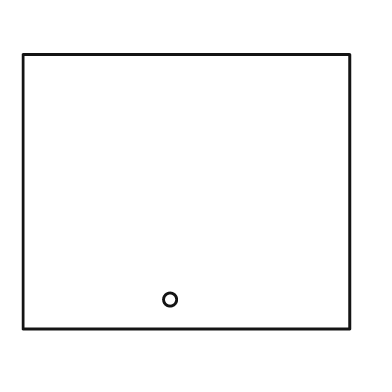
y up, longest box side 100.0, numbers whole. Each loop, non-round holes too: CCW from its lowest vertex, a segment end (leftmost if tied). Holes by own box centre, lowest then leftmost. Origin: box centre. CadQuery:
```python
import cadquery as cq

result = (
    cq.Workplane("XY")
    .moveTo(-50.0, -42.0)
    .lineTo(50.0, -42.0)
    .lineTo(50.0, 42.0)
    .lineTo(-50.0, 42.0)
    .close()
    .moveTo(-5.0, -33.0)
    .circle(2.0)
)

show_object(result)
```